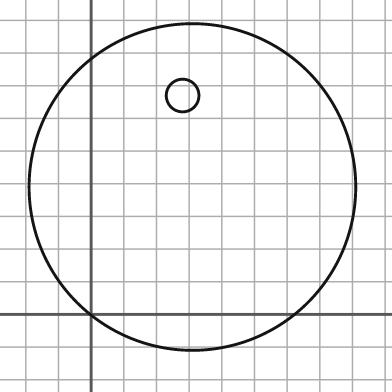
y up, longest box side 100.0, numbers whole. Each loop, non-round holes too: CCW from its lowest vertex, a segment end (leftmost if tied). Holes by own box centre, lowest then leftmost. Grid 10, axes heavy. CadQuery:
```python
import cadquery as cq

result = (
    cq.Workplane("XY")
    .moveTo(31.0, 39.0)
    .circle(50.0)
    .moveTo(28.0, 67.0)
    .circle(5.0)
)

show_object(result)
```